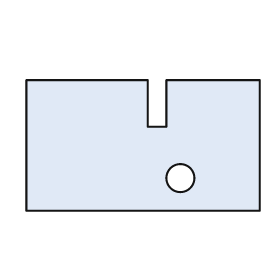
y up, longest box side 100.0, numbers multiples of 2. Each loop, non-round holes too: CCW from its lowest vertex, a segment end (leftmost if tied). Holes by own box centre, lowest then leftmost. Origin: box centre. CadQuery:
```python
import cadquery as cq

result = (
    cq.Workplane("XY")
    .moveTo(-50.0, -28.0)
    .lineTo(50.0, -28.0)
    .lineTo(50.0, 28.0)
    .lineTo(10.0, 28.0)
    .lineTo(10.0, 8.0)
    .lineTo(2.0, 8.0)
    .lineTo(2.0, 28.0)
    .lineTo(-50.0, 28.0)
    .close()
    .moveTo(16.0, -14.0)
    .circle(6.0)
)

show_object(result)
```